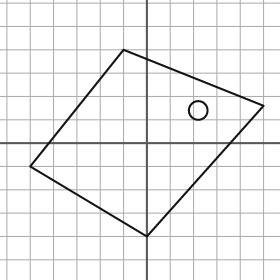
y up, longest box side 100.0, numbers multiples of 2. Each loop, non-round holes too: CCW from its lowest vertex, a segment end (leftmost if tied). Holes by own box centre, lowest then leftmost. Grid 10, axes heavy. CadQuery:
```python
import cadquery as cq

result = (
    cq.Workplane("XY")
    .moveTo(0.0, -40.0)
    .lineTo(50.0, 16.0)
    .lineTo(-10.0, 40.0)
    .lineTo(-50.0, -10.0)
    .close()
    .moveTo(22.0, 14.0)
    .circle(4.0)
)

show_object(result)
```